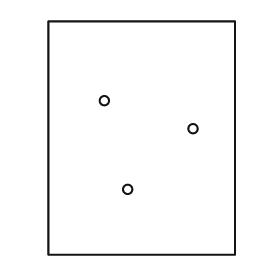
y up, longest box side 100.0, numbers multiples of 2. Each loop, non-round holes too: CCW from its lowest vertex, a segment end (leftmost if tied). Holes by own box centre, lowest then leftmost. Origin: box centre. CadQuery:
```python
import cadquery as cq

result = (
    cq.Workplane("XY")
    .moveTo(-40.0, -50.0)
    .lineTo(40.0, -50.0)
    .lineTo(40.0, 50.0)
    .lineTo(-40.0, 50.0)
    .close()
    .moveTo(-6.0, -22.0)
    .circle(2.0)
    .moveTo(22.0, 4.0)
    .circle(2.0)
    .moveTo(-16.0, 16.0)
    .circle(2.0)
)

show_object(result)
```